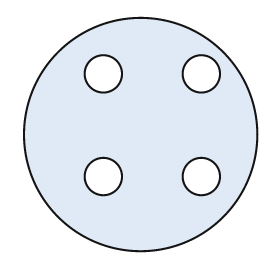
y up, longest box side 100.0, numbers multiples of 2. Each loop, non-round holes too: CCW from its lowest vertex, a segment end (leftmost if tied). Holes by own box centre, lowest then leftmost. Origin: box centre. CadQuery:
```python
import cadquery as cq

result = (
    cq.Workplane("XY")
    .moveTo(0.0, 0.0)
    .circle(50.0)
    .moveTo(-16.0, -18.0)
    .circle(8.0)
    .moveTo(26.0, -18.0)
    .circle(8.0)
    .moveTo(-16.0, 26.0)
    .circle(8.0)
    .moveTo(26.0, 26.0)
    .circle(8.0)
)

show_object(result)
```